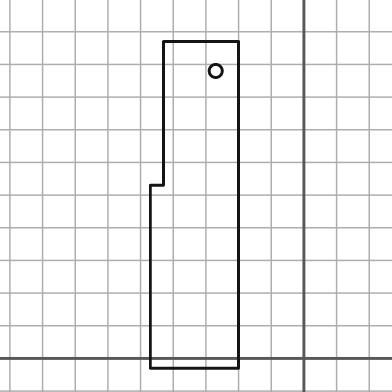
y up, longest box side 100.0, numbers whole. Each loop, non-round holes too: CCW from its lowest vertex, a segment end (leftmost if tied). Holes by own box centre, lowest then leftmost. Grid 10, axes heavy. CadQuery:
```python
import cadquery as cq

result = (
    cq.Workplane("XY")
    .moveTo(-47.0, -3.0)
    .lineTo(-20.0, -3.0)
    .lineTo(-20.0, 97.0)
    .lineTo(-43.0, 97.0)
    .lineTo(-43.0, 53.0)
    .lineTo(-47.0, 53.0)
    .close()
    .moveTo(-27.0, 88.0)
    .circle(2.0)
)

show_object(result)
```